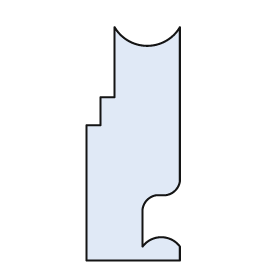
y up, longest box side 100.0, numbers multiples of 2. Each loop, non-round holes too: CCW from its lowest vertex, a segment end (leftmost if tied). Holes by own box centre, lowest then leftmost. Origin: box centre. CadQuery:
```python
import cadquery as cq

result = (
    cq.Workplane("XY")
    .moveTo(-20.0, -50.0)
    .lineTo(20.0, -50.0)
    .lineTo(20.0, -44.0)
    .threePointArc((12.0, -40.0), (4.0, -44.0))
    .lineTo(4.0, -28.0)
    .threePointArc((6.0, -24.0), (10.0, -22.0))
    .lineTo(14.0, -22.0)
    .threePointArc((18.0, -20.0), (20.0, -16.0))
    .lineTo(20.0, 50.0)
    .threePointArc((6.0, 42.0), (-8.0, 50.0))
    .lineTo(-8.0, 20.0)
    .lineTo(-14.0, 20.0)
    .lineTo(-14.0, 8.0)
    .lineTo(-20.0, 8.0)
    .close()
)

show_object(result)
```